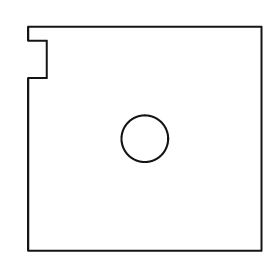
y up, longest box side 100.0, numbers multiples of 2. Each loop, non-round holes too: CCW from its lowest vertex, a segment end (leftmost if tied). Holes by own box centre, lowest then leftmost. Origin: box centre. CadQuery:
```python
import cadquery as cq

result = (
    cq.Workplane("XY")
    .moveTo(-50.0, -48.0)
    .lineTo(50.0, -48.0)
    .lineTo(50.0, 48.0)
    .lineTo(-50.0, 48.0)
    .lineTo(-50.0, 42.0)
    .lineTo(-42.0, 42.0)
    .lineTo(-42.0, 26.0)
    .lineTo(-50.0, 26.0)
    .close()
    .moveTo(0.0, 0.0)
    .circle(10.0)
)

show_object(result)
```